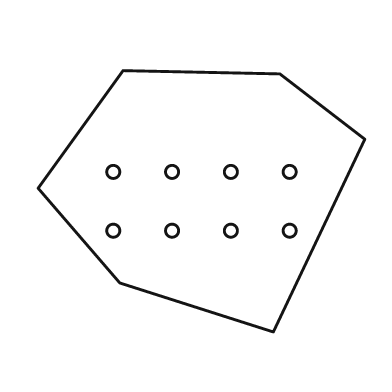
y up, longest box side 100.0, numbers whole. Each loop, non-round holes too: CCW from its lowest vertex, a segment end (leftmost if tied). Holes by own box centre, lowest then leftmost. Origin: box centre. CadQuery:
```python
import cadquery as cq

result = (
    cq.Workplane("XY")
    .moveTo(22.0, -40.0)
    .lineTo(50.0, 19.0)
    .lineTo(24.0, 39.0)
    .lineTo(-24.0, 40.0)
    .lineTo(-50.0, 4.0)
    .lineTo(-25.0, -25.0)
    .close()
    .moveTo(-27.0, -9.0)
    .circle(2.0)
    .moveTo(-9.0, -9.0)
    .circle(2.0)
    .moveTo(9.0, -9.0)
    .circle(2.0)
    .moveTo(27.0, -9.0)
    .circle(2.0)
    .moveTo(-27.0, 9.0)
    .circle(2.0)
    .moveTo(-9.0, 9.0)
    .circle(2.0)
    .moveTo(9.0, 9.0)
    .circle(2.0)
    .moveTo(27.0, 9.0)
    .circle(2.0)
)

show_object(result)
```